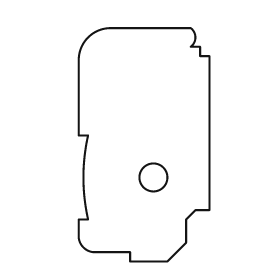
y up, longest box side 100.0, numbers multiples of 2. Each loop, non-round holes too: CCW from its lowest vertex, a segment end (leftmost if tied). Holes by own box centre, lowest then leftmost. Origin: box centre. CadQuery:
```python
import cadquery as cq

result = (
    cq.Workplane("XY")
    .moveTo(-6.0, -50.0)
    .lineTo(10.0, -50.0)
    .lineTo(18.0, -42.0)
    .lineTo(18.0, -32.0)
    .lineTo(22.0, -28.0)
    .lineTo(28.0, -28.0)
    .lineTo(28.0, 38.0)
    .lineTo(24.0, 38.0)
    .lineTo(24.0, 42.0)
    .lineTo(20.0, 42.0)
    .threePointArc((22.0, 46.0), (20.0, 50.0))
    .lineTo(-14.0, 50.0)
    .threePointArc((-24.0, 46.0), (-28.0, 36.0))
    .lineTo(-28.0, 4.0)
    .lineTo(-24.0, 4.0)
    .threePointArc((-26.0, -14.0), (-24.0, -32.0))
    .lineTo(-28.0, -32.0)
    .lineTo(-28.0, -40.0)
    .threePointArc((-26.0, -44.0), (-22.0, -46.0))
    .lineTo(-6.0, -46.0)
    .close()
    .moveTo(4.0, -14.0)
    .circle(6.0)
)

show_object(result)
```